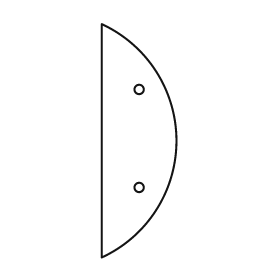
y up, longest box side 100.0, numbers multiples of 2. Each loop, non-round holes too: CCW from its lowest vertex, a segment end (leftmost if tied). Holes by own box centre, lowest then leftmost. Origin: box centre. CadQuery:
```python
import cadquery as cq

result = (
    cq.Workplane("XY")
    .moveTo(-16.0, -50.0)
    .threePointArc((16.0, 0.0), (-16.0, 50.0))
    .close()
    .moveTo(0.0, -20.0)
    .circle(2.0)
    .moveTo(0.0, 22.0)
    .circle(2.0)
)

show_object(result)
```